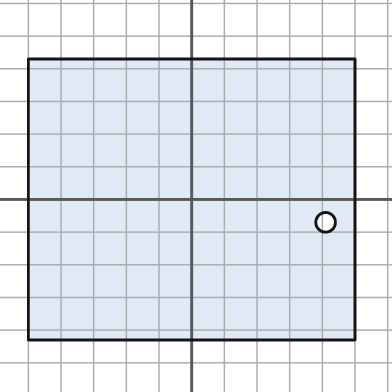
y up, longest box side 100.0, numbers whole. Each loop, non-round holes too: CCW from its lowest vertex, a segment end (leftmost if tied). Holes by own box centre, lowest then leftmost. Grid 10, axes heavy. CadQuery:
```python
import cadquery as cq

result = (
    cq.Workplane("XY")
    .moveTo(-50.0, -43.0)
    .lineTo(50.0, -43.0)
    .lineTo(50.0, 43.0)
    .lineTo(-50.0, 43.0)
    .close()
    .moveTo(41.0, -7.0)
    .circle(3.0)
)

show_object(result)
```